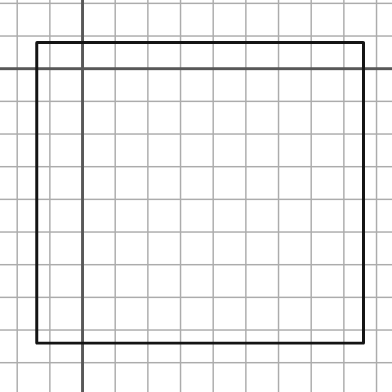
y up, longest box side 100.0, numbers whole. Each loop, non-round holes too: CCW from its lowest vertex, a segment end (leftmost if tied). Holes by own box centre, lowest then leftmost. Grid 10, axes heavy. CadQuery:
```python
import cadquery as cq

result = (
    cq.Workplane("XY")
    .moveTo(-14.0, -84.0)
    .lineTo(86.0, -84.0)
    .lineTo(86.0, 8.0)
    .lineTo(-14.0, 8.0)
    .close()
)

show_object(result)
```